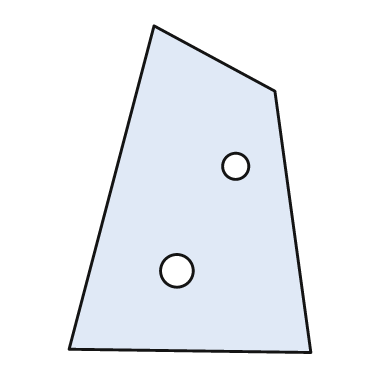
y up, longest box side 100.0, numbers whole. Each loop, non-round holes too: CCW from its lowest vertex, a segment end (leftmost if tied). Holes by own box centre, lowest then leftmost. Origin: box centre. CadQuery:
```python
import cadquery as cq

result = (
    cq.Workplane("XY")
    .moveTo(37.0, -50.0)
    .lineTo(26.0, 30.0)
    .lineTo(-11.0, 50.0)
    .lineTo(-37.0, -49.0)
    .close()
    .moveTo(-4.0, -25.0)
    .circle(5.0)
    .moveTo(14.0, 7.0)
    .circle(4.0)
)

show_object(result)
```